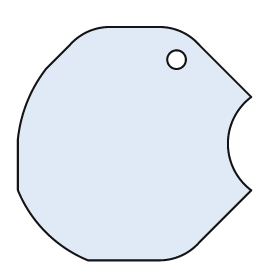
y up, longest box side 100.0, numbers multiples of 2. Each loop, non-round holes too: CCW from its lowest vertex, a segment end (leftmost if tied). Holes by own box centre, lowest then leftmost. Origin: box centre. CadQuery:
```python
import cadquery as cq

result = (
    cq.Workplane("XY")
    .moveTo(-20.0, -50.0)
    .lineTo(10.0, -50.0)
    .threePointArc((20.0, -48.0), (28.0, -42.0))
    .lineTo(50.0, -20.0)
    .threePointArc((40.0, 0.0), (50.0, 20.0))
    .lineTo(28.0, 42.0)
    .threePointArc((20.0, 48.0), (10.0, 50.0))
    .lineTo(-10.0, 50.0)
    .threePointArc((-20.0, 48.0), (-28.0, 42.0))
    .lineTo(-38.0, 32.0)
    .threePointArc((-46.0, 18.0), (-50.0, 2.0))
    .lineTo(-50.0, -20.0)
    .threePointArc((-38.0, -38.0), (-20.0, -50.0))
    .close()
    .moveTo(18.0, 36.0)
    .circle(4.0)
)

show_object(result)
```